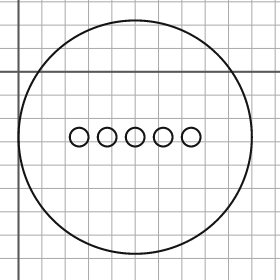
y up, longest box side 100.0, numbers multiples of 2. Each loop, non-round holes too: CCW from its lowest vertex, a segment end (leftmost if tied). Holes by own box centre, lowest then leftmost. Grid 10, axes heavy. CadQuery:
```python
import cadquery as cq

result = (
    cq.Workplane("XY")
    .moveTo(50.0, -28.0)
    .circle(50.0)
    .moveTo(26.0, -28.0)
    .circle(4.0)
    .moveTo(38.0, -28.0)
    .circle(4.0)
    .moveTo(50.0, -28.0)
    .circle(4.0)
    .moveTo(62.0, -28.0)
    .circle(4.0)
    .moveTo(74.0, -28.0)
    .circle(4.0)
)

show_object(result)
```